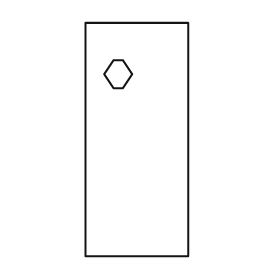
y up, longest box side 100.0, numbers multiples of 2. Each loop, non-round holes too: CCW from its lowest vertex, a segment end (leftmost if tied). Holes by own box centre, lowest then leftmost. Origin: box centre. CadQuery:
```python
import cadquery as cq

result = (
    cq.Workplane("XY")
    .moveTo(-22.0, -50.0)
    .lineTo(22.0, -50.0)
    .lineTo(22.0, 50.0)
    .lineTo(-22.0, 50.0)
    .close()
    .moveTo(-10.0, 22.0)
    .lineTo(-6.0, 22.0)
    .lineTo(-2.0, 28.0)
    .lineTo(-6.0, 34.0)
    .lineTo(-10.0, 34.0)
    .lineTo(-14.0, 28.0)
    .close()
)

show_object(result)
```